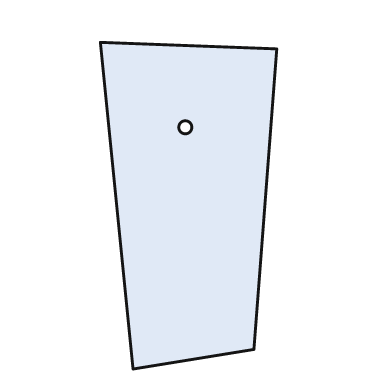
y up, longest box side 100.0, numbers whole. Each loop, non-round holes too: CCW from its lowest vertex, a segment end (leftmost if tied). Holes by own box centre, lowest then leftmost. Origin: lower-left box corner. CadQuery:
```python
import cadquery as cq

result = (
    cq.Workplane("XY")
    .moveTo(10.0, 0.0)
    .lineTo(47.0, 6.0)
    .lineTo(54.0, 98.0)
    .lineTo(0.0, 100.0)
    .close()
    .moveTo(26.0, 74.0)
    .circle(2.0)
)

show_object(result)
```